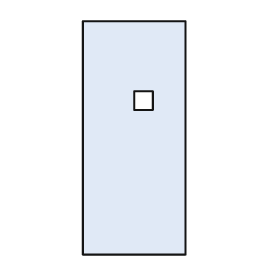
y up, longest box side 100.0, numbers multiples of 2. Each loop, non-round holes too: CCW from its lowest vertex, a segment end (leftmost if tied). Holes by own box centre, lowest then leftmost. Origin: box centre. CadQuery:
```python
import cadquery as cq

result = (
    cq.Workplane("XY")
    .moveTo(-22.0, -50.0)
    .lineTo(22.0, -50.0)
    .lineTo(22.0, 50.0)
    .lineTo(-22.0, 50.0)
    .close()
    .moveTo(0.0, 12.0)
    .lineTo(8.0, 12.0)
    .lineTo(8.0, 20.0)
    .lineTo(0.0, 20.0)
    .close()
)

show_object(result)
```